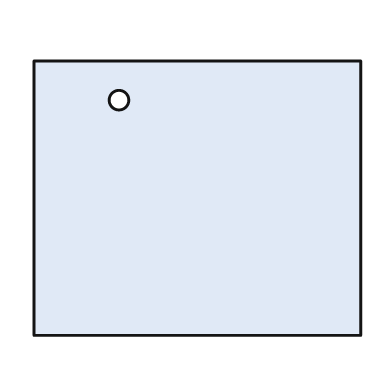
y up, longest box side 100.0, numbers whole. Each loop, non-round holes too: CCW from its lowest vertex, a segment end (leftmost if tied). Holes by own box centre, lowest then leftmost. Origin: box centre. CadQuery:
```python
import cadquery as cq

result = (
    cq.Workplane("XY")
    .moveTo(-50.0, -42.0)
    .lineTo(50.0, -42.0)
    .lineTo(50.0, 42.0)
    .lineTo(-50.0, 42.0)
    .close()
    .moveTo(-24.0, 30.0)
    .circle(3.0)
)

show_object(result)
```